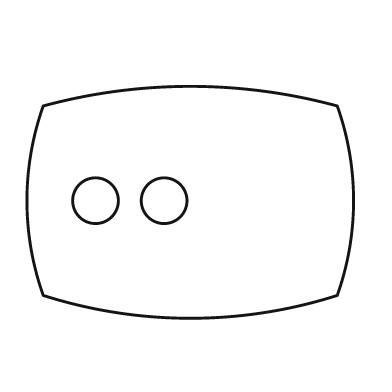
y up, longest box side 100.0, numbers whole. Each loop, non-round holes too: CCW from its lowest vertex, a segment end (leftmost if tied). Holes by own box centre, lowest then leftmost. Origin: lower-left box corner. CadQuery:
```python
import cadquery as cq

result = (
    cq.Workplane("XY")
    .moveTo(5.0, 7.0)
    .threePointArc((50.0, 0.0), (95.0, 7.0))
    .threePointArc((100.0, 36.0), (95.0, 65.0))
    .threePointArc((50.0, 71.0), (5.0, 65.0))
    .threePointArc((0.0, 36.0), (5.0, 7.0))
    .close()
    .moveTo(21.0, 36.0)
    .circle(7.0)
    .moveTo(42.0, 36.0)
    .circle(7.0)
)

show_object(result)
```